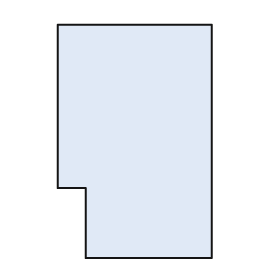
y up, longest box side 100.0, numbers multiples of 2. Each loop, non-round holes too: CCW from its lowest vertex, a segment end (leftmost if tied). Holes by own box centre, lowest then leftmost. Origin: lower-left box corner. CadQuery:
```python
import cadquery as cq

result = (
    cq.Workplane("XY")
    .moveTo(12.0, 0.0)
    .lineTo(66.0, 0.0)
    .lineTo(66.0, 100.0)
    .lineTo(0.0, 100.0)
    .lineTo(0.0, 30.0)
    .lineTo(12.0, 30.0)
    .close()
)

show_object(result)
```